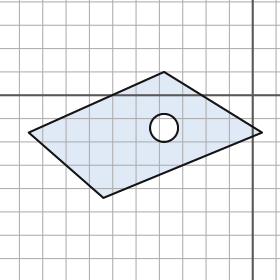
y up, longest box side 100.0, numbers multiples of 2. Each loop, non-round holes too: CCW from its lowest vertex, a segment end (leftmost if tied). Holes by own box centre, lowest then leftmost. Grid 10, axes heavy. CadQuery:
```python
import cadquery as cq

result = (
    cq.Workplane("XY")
    .moveTo(-64.0, -44.0)
    .lineTo(4.0, -16.0)
    .lineTo(-38.0, 10.0)
    .lineTo(-96.0, -16.0)
    .close()
    .moveTo(-38.0, -14.0)
    .circle(6.0)
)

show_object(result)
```